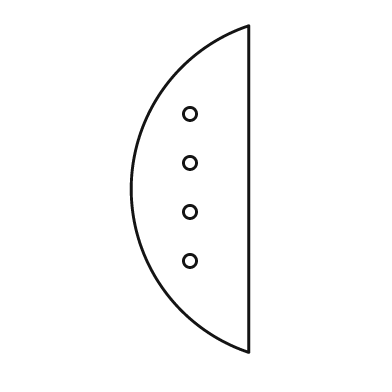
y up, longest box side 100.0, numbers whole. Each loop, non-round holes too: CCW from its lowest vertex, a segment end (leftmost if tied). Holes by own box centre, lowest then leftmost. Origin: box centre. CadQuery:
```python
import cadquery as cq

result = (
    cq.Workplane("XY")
    .moveTo(18.0, -50.0)
    .lineTo(18.0, 50.0)
    .threePointArc((-18.0, 0.0), (18.0, -50.0))
    .close()
    .moveTo(0.0, -22.0)
    .circle(2.0)
    .moveTo(0.0, -7.0)
    .circle(2.0)
    .moveTo(0.0, 8.0)
    .circle(2.0)
    .moveTo(0.0, 23.0)
    .circle(2.0)
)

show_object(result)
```